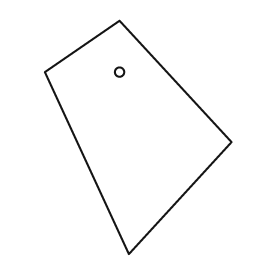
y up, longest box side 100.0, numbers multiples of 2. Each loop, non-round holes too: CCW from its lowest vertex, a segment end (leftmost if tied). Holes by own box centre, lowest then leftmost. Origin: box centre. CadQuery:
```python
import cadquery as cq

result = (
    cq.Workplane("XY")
    .moveTo(-4.0, -50.0)
    .lineTo(40.0, -2.0)
    .lineTo(-8.0, 50.0)
    .lineTo(-40.0, 28.0)
    .close()
    .moveTo(-8.0, 28.0)
    .circle(2.0)
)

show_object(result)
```